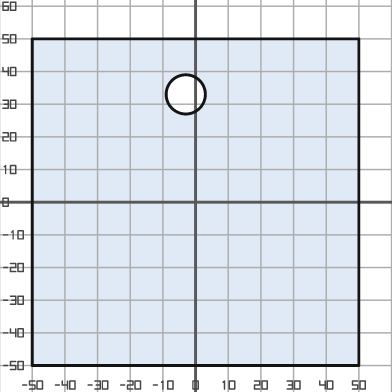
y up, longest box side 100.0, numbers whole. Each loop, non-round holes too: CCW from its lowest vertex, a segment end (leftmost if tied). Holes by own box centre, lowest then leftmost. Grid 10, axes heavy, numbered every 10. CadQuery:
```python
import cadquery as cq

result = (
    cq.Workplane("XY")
    .moveTo(-50.0, -50.0)
    .lineTo(50.0, -50.0)
    .lineTo(50.0, 50.0)
    .lineTo(-50.0, 50.0)
    .close()
    .moveTo(-3.0, 33.0)
    .circle(6.0)
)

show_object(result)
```